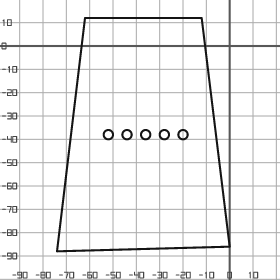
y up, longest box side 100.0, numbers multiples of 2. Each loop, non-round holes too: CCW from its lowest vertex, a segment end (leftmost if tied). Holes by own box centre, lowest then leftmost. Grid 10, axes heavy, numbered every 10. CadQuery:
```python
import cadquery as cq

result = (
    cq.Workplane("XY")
    .moveTo(-74.0, -88.0)
    .lineTo(0.0, -86.0)
    .lineTo(-12.0, 12.0)
    .lineTo(-62.0, 12.0)
    .close()
    .moveTo(-52.0, -38.0)
    .circle(2.0)
    .moveTo(-44.0, -38.0)
    .circle(2.0)
    .moveTo(-36.0, -38.0)
    .circle(2.0)
    .moveTo(-28.0, -38.0)
    .circle(2.0)
    .moveTo(-20.0, -38.0)
    .circle(2.0)
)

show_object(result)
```